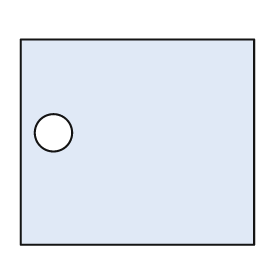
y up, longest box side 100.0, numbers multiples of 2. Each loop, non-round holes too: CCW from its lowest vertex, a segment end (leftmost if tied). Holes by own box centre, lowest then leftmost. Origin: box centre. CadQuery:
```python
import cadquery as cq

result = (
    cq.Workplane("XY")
    .moveTo(-50.0, -44.0)
    .lineTo(50.0, -44.0)
    .lineTo(50.0, 44.0)
    .lineTo(-50.0, 44.0)
    .close()
    .moveTo(-36.0, 4.0)
    .circle(8.0)
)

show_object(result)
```